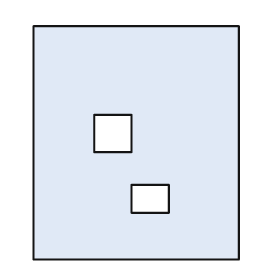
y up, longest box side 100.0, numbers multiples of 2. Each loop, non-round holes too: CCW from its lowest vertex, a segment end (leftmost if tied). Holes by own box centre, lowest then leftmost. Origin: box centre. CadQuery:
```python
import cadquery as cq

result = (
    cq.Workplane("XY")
    .moveTo(-44.0, -50.0)
    .lineTo(44.0, -50.0)
    .lineTo(44.0, 50.0)
    .lineTo(-44.0, 50.0)
    .close()
    .moveTo(-2.0, -30.0)
    .lineTo(14.0, -30.0)
    .lineTo(14.0, -18.0)
    .lineTo(-2.0, -18.0)
    .close()
    .moveTo(-18.0, -4.0)
    .lineTo(-2.0, -4.0)
    .lineTo(-2.0, 12.0)
    .lineTo(-18.0, 12.0)
    .close()
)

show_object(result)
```